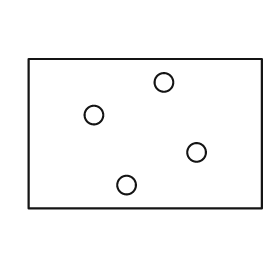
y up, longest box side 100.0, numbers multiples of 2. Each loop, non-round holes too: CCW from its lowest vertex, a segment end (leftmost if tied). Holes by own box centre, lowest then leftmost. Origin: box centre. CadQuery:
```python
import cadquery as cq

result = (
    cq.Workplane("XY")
    .moveTo(-50.0, -32.0)
    .lineTo(50.0, -32.0)
    .lineTo(50.0, 32.0)
    .lineTo(-50.0, 32.0)
    .close()
    .moveTo(-8.0, -22.0)
    .circle(4.0)
    .moveTo(22.0, -8.0)
    .circle(4.0)
    .moveTo(-22.0, 8.0)
    .circle(4.0)
    .moveTo(8.0, 22.0)
    .circle(4.0)
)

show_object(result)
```